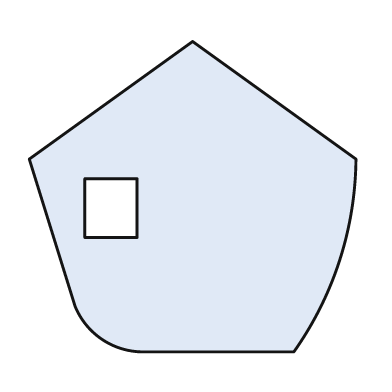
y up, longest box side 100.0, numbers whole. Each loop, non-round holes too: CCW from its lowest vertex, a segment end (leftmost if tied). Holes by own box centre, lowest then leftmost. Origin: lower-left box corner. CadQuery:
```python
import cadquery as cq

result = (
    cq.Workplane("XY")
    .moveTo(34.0, 0.0)
    .lineTo(81.0, 0.0)
    .threePointArc((95.0, 28.0), (100.0, 59.0))
    .lineTo(50.0, 95.0)
    .lineTo(0.0, 59.0)
    .lineTo(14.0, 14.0)
    .threePointArc((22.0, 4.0), (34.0, 0.0))
    .close()
    .moveTo(17.0, 35.0)
    .lineTo(33.0, 35.0)
    .lineTo(33.0, 53.0)
    .lineTo(17.0, 53.0)
    .close()
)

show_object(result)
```